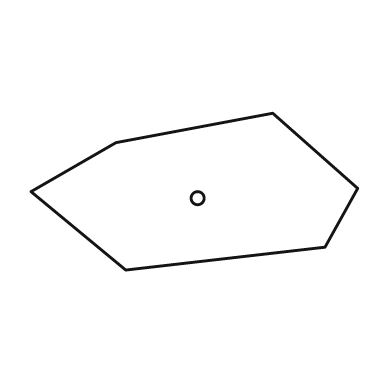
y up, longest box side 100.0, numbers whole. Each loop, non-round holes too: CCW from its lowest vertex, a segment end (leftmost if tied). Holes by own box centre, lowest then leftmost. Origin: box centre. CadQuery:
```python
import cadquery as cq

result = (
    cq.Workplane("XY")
    .moveTo(-21.0, -24.0)
    .lineTo(40.0, -17.0)
    .lineTo(50.0, 1.0)
    .lineTo(24.0, 24.0)
    .lineTo(-24.0, 15.0)
    .lineTo(-50.0, 0.0)
    .close()
    .moveTo(1.0, -2.0)
    .circle(2.0)
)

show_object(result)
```